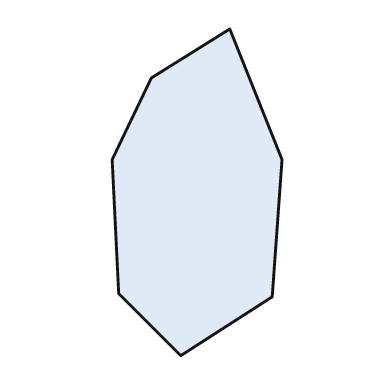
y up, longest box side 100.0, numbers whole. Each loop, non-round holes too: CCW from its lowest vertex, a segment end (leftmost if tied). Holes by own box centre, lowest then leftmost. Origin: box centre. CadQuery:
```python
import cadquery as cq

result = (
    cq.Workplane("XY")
    .moveTo(-5.0, -50.0)
    .lineTo(23.0, -32.0)
    .lineTo(26.0, 10.0)
    .lineTo(10.0, 50.0)
    .lineTo(-14.0, 35.0)
    .lineTo(-26.0, 10.0)
    .lineTo(-24.0, -31.0)
    .close()
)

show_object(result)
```